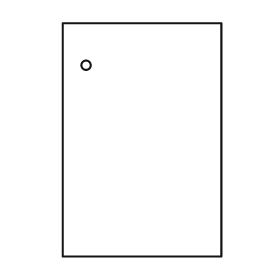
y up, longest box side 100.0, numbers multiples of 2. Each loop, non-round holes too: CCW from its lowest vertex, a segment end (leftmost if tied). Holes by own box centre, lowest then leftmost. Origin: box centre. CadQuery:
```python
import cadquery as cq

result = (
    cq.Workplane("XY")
    .moveTo(-34.0, -50.0)
    .lineTo(34.0, -50.0)
    .lineTo(34.0, 50.0)
    .lineTo(-34.0, 50.0)
    .close()
    .moveTo(-24.0, 32.0)
    .circle(2.0)
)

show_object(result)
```